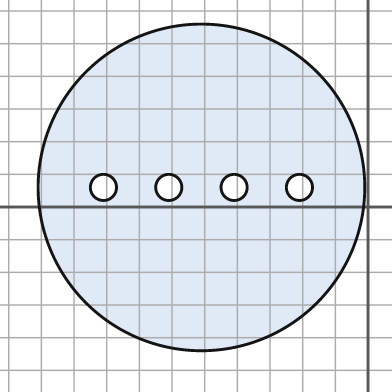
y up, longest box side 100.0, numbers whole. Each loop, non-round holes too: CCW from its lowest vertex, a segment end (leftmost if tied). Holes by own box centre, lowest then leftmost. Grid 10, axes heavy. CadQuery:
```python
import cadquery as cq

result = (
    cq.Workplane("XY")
    .moveTo(-51.0, 6.0)
    .circle(50.0)
    .moveTo(-81.0, 6.0)
    .circle(4.0)
    .moveTo(-61.0, 6.0)
    .circle(4.0)
    .moveTo(-41.0, 6.0)
    .circle(4.0)
    .moveTo(-21.0, 6.0)
    .circle(4.0)
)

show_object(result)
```